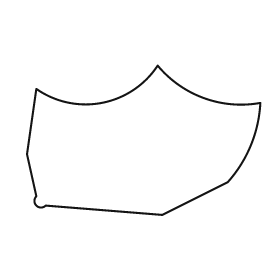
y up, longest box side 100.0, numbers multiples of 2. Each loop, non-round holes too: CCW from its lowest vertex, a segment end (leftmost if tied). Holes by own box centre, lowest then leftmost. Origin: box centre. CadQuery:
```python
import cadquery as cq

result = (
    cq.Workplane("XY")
    .moveTo(8.0, -32.0)
    .lineTo(36.0, -18.0)
    .threePointArc((46.0, -2.0), (50.0, 16.0))
    .threePointArc((26.0, 18.0), (6.0, 32.0))
    .threePointArc((-18.0, 16.0), (-46.0, 22.0))
    .lineTo(-50.0, -6.0)
    .lineTo(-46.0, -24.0)
    .threePointArc((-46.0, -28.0), (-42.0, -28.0))
    .close()
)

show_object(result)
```